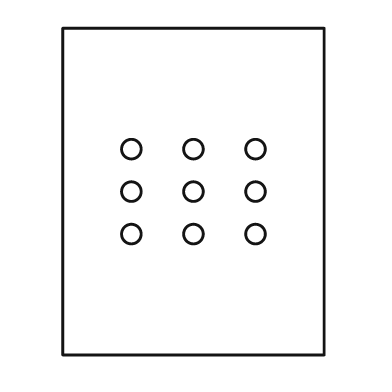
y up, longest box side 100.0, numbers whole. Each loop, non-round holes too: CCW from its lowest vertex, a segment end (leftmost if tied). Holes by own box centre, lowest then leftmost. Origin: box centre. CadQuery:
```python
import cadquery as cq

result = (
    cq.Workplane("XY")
    .moveTo(-40.0, -50.0)
    .lineTo(40.0, -50.0)
    .lineTo(40.0, 50.0)
    .lineTo(-40.0, 50.0)
    .close()
    .moveTo(-19.0, -13.0)
    .circle(3.0)
    .moveTo(0.0, -13.0)
    .circle(3.0)
    .moveTo(19.0, -13.0)
    .circle(3.0)
    .moveTo(-19.0, 0.0)
    .circle(3.0)
    .moveTo(0.0, 0.0)
    .circle(3.0)
    .moveTo(19.0, 0.0)
    .circle(3.0)
    .moveTo(-19.0, 13.0)
    .circle(3.0)
    .moveTo(0.0, 13.0)
    .circle(3.0)
    .moveTo(19.0, 13.0)
    .circle(3.0)
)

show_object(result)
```